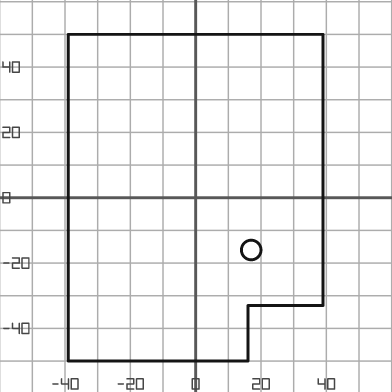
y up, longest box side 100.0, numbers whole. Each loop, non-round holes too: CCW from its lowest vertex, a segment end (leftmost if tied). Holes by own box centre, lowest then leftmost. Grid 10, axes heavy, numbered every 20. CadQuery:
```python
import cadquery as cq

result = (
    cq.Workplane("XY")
    .moveTo(-39.0, -50.0)
    .lineTo(16.0, -50.0)
    .lineTo(16.0, -33.0)
    .lineTo(39.0, -33.0)
    .lineTo(39.0, 50.0)
    .lineTo(-39.0, 50.0)
    .close()
    .moveTo(17.0, -16.0)
    .circle(3.0)
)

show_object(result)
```